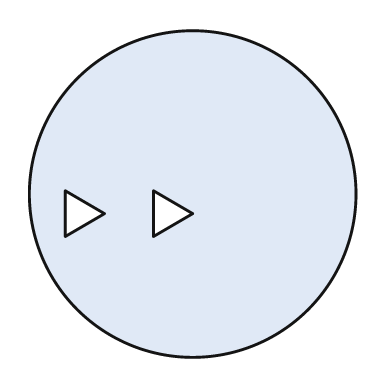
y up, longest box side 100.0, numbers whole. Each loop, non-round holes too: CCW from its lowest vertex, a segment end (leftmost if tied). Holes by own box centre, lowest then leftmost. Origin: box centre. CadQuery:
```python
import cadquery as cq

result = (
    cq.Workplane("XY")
    .moveTo(0.0, 0.0)
    .circle(50.0)
    .moveTo(-39.0, -13.0)
    .lineTo(-27.0, -6.0)
    .lineTo(-39.0, 1.0)
    .close()
    .moveTo(-12.0, -13.0)
    .lineTo(0.0, -6.0)
    .lineTo(-12.0, 1.0)
    .close()
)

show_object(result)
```